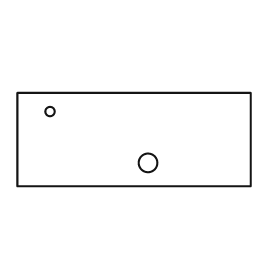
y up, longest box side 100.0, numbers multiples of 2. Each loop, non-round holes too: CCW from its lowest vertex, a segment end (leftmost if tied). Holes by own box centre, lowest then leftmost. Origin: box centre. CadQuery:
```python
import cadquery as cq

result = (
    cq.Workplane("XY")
    .moveTo(-50.0, -20.0)
    .lineTo(50.0, -20.0)
    .lineTo(50.0, 20.0)
    .lineTo(-50.0, 20.0)
    .close()
    .moveTo(6.0, -10.0)
    .circle(4.0)
    .moveTo(-36.0, 12.0)
    .circle(2.0)
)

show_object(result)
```